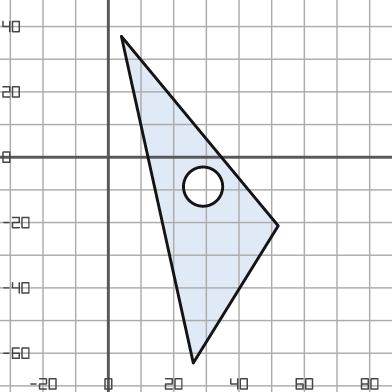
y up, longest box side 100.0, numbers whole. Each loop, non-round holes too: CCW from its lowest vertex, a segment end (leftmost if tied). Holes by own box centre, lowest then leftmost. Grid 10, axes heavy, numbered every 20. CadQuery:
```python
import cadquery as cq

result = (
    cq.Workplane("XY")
    .moveTo(26.0, -63.0)
    .lineTo(52.0, -21.0)
    .lineTo(4.0, 37.0)
    .close()
    .moveTo(29.0, -9.0)
    .circle(6.0)
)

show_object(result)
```